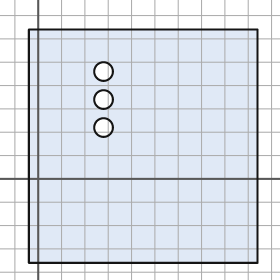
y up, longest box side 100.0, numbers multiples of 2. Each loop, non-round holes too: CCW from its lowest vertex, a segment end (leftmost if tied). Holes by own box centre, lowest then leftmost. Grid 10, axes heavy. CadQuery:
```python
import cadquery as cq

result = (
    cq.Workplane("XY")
    .moveTo(-4.0, -36.0)
    .lineTo(94.0, -36.0)
    .lineTo(94.0, 64.0)
    .lineTo(-4.0, 64.0)
    .close()
    .moveTo(28.0, 22.0)
    .circle(4.0)
    .moveTo(28.0, 34.0)
    .circle(4.0)
    .moveTo(28.0, 46.0)
    .circle(4.0)
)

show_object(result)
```